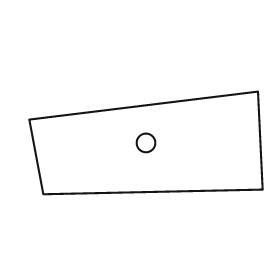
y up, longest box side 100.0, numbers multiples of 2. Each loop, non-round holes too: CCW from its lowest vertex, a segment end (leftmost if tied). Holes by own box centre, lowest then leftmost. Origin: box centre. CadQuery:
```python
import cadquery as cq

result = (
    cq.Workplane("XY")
    .moveTo(-44.0, -22.0)
    .lineTo(50.0, -20.0)
    .lineTo(48.0, 22.0)
    .lineTo(-50.0, 10.0)
    .close()
    .moveTo(0.0, 0.0)
    .circle(4.0)
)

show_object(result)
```